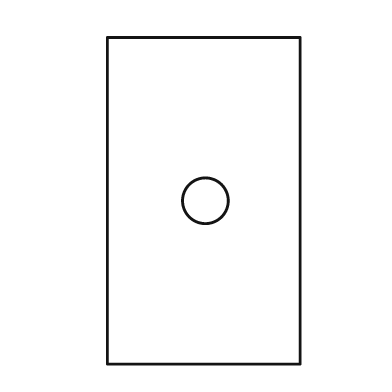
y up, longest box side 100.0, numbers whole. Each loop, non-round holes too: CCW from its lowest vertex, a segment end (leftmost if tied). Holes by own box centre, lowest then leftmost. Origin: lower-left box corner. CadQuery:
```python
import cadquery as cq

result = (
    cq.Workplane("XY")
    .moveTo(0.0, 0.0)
    .lineTo(59.0, 0.0)
    .lineTo(59.0, 100.0)
    .lineTo(0.0, 100.0)
    .close()
    .moveTo(30.0, 50.0)
    .circle(7.0)
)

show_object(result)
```